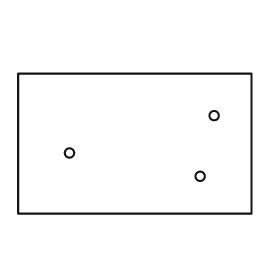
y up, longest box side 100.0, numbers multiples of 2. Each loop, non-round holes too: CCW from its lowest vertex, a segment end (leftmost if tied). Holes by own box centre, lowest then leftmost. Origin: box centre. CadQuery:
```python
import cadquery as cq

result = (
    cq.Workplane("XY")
    .moveTo(-50.0, -30.0)
    .lineTo(50.0, -30.0)
    .lineTo(50.0, 30.0)
    .lineTo(-50.0, 30.0)
    .close()
    .moveTo(28.0, -14.0)
    .circle(2.0)
    .moveTo(-28.0, -4.0)
    .circle(2.0)
    .moveTo(34.0, 12.0)
    .circle(2.0)
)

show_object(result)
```